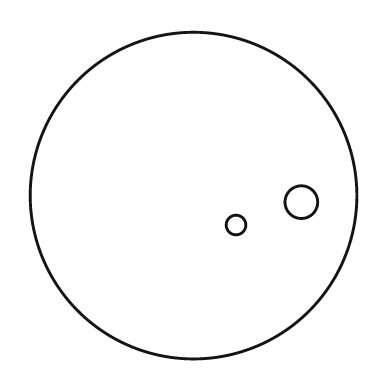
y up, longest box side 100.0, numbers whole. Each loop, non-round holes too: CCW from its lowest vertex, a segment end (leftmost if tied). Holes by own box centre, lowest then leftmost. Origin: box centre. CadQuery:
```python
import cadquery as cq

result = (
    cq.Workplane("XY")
    .moveTo(0.0, 0.0)
    .circle(50.0)
    .moveTo(13.0, -9.0)
    .circle(3.0)
    .moveTo(33.0, -2.0)
    .circle(5.0)
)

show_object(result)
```